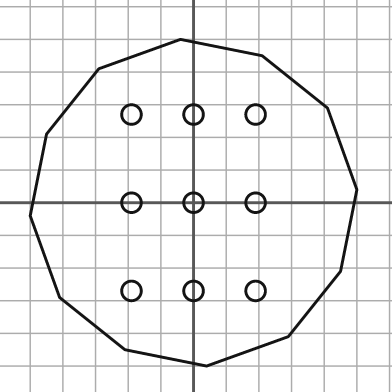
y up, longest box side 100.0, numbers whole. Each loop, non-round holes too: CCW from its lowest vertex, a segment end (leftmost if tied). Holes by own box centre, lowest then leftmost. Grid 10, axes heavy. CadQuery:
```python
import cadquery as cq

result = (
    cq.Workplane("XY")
    .moveTo(4.0, -50.0)
    .lineTo(29.0, -41.0)
    .lineTo(45.0, -21.0)
    .lineTo(50.0, 4.0)
    .lineTo(41.0, 29.0)
    .lineTo(21.0, 45.0)
    .lineTo(-4.0, 50.0)
    .lineTo(-29.0, 41.0)
    .lineTo(-45.0, 21.0)
    .lineTo(-50.0, -4.0)
    .lineTo(-41.0, -29.0)
    .lineTo(-21.0, -45.0)
    .close()
    .moveTo(-19.0, -27.0)
    .circle(3.0)
    .moveTo(0.0, -27.0)
    .circle(3.0)
    .moveTo(19.0, -27.0)
    .circle(3.0)
    .moveTo(-19.0, 0.0)
    .circle(3.0)
    .moveTo(0.0, 0.0)
    .circle(3.0)
    .moveTo(19.0, 0.0)
    .circle(3.0)
    .moveTo(-19.0, 27.0)
    .circle(3.0)
    .moveTo(0.0, 27.0)
    .circle(3.0)
    .moveTo(19.0, 27.0)
    .circle(3.0)
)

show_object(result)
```